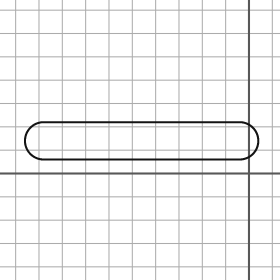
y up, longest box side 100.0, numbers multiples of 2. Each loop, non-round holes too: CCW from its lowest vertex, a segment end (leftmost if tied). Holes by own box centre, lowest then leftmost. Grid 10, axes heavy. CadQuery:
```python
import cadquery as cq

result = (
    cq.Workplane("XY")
    .moveTo(-88.0, 6.0)
    .lineTo(-4.0, 6.0)
    .threePointArc((4.0, 14.0), (-4.0, 22.0))
    .lineTo(-88.0, 22.0)
    .threePointArc((-96.0, 14.0), (-88.0, 6.0))
    .close()
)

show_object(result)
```